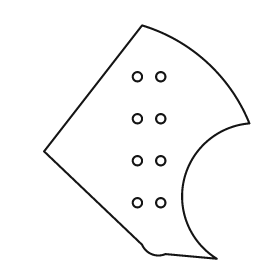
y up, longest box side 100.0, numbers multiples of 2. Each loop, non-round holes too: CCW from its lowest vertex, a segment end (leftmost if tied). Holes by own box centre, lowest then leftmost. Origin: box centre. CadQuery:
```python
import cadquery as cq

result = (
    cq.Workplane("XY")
    .moveTo(30.0, -50.0)
    .threePointArc((16.0, -16.0), (44.0, 8.0))
    .threePointArc((26.0, 34.0), (-2.0, 50.0))
    .lineTo(-44.0, -4.0)
    .lineTo(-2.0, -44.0)
    .threePointArc((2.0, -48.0), (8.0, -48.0))
    .close()
    .moveTo(-4.0, -26.0)
    .circle(2.0)
    .moveTo(6.0, -26.0)
    .circle(2.0)
    .moveTo(-4.0, -8.0)
    .circle(2.0)
    .moveTo(6.0, -8.0)
    .circle(2.0)
    .moveTo(-4.0, 10.0)
    .circle(2.0)
    .moveTo(6.0, 10.0)
    .circle(2.0)
    .moveTo(-4.0, 28.0)
    .circle(2.0)
    .moveTo(6.0, 28.0)
    .circle(2.0)
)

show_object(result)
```